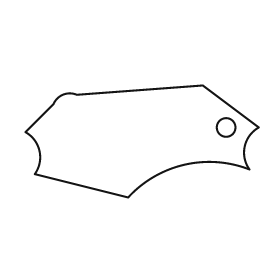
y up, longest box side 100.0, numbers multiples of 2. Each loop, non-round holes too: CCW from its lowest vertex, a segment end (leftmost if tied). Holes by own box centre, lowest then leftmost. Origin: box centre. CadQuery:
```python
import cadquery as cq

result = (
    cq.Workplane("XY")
    .moveTo(-6.0, -24.0)
    .threePointArc((18.0, -10.0), (46.0, -12.0))
    .threePointArc((44.0, -2.0), (50.0, 6.0))
    .lineTo(26.0, 24.0)
    .lineTo(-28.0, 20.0)
    .threePointArc((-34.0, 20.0), (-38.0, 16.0))
    .lineTo(-50.0, 4.0)
    .threePointArc((-44.0, -4.0), (-46.0, -14.0))
    .close()
    .moveTo(36.0, 6.0)
    .circle(4.0)
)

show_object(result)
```